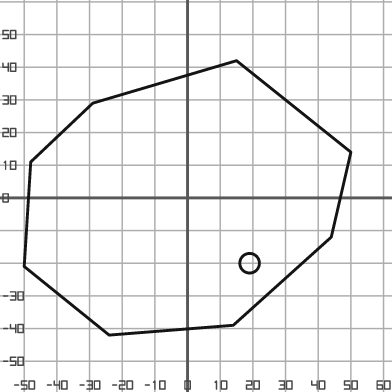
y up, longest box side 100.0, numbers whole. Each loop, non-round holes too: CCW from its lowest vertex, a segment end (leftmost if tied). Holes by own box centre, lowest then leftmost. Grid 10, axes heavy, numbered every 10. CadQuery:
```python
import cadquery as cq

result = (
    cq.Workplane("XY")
    .moveTo(-24.0, -42.0)
    .lineTo(14.0, -39.0)
    .lineTo(44.0, -12.0)
    .lineTo(50.0, 14.0)
    .lineTo(15.0, 42.0)
    .lineTo(-29.0, 29.0)
    .lineTo(-48.0, 11.0)
    .lineTo(-50.0, -21.0)
    .close()
    .moveTo(19.0, -20.0)
    .circle(3.0)
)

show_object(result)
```